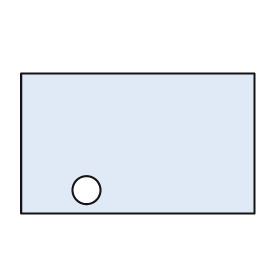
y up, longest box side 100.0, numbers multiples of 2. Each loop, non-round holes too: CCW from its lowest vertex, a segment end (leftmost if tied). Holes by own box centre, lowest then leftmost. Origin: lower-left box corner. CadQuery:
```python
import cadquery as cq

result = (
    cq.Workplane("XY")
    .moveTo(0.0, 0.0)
    .lineTo(100.0, 0.0)
    .lineTo(100.0, 60.0)
    .lineTo(0.0, 60.0)
    .close()
    .moveTo(28.0, 10.0)
    .circle(6.0)
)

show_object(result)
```